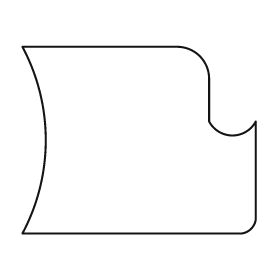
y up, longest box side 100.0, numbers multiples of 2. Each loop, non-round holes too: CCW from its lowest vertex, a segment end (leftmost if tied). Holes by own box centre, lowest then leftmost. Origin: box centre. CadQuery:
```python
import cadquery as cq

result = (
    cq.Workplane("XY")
    .moveTo(-50.0, -40.0)
    .lineTo(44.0, -40.0)
    .threePointArc((48.0, -38.0), (50.0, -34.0))
    .lineTo(50.0, 8.0)
    .threePointArc((40.0, 2.0), (30.0, 8.0))
    .lineTo(30.0, 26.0)
    .threePointArc((26.0, 36.0), (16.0, 40.0))
    .lineTo(-50.0, 40.0)
    .threePointArc((-40.0, 0.0), (-50.0, -40.0))
    .close()
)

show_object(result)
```